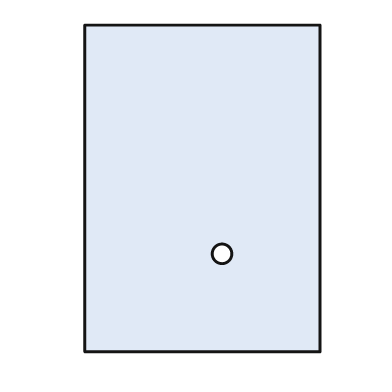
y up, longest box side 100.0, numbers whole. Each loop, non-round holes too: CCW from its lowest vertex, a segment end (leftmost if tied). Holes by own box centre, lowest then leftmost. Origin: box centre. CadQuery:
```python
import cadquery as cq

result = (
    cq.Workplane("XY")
    .moveTo(-36.0, -50.0)
    .lineTo(36.0, -50.0)
    .lineTo(36.0, 50.0)
    .lineTo(-36.0, 50.0)
    .close()
    .moveTo(6.0, -20.0)
    .circle(3.0)
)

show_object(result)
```